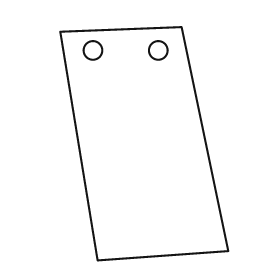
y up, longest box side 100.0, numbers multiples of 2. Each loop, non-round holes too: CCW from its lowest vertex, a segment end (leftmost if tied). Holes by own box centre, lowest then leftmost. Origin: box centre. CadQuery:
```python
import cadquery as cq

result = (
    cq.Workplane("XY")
    .moveTo(-20.0, -50.0)
    .lineTo(36.0, -46.0)
    .lineTo(16.0, 50.0)
    .lineTo(-36.0, 48.0)
    .close()
    .moveTo(-22.0, 40.0)
    .circle(4.0)
    .moveTo(6.0, 40.0)
    .circle(4.0)
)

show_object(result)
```